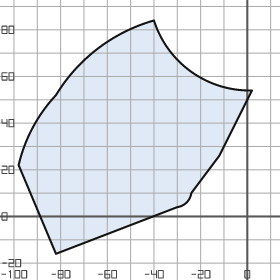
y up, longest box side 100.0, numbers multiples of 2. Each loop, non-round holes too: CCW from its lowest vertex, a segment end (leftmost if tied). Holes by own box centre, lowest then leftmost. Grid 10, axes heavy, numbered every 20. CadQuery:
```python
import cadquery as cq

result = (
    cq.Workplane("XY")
    .moveTo(-82.0, -16.0)
    .lineTo(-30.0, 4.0)
    .threePointArc((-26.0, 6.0), (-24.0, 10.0))
    .lineTo(-12.0, 26.0)
    .lineTo(2.0, 54.0)
    .threePointArc((-24.0, 62.0), (-40.0, 84.0))
    .threePointArc((-64.0, 72.0), (-82.0, 52.0))
    .threePointArc((-92.0, 38.0), (-98.0, 22.0))
    .close()
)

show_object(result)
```